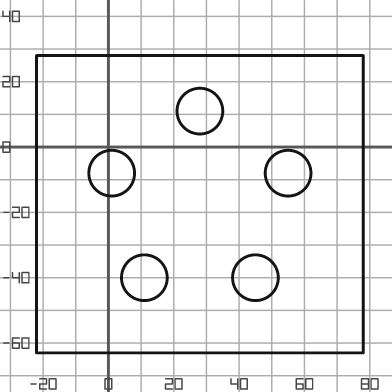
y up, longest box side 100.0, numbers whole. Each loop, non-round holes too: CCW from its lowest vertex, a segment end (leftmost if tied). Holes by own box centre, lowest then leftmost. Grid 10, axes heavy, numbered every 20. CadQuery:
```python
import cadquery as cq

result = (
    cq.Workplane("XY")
    .moveTo(-22.0, -63.0)
    .lineTo(78.0, -63.0)
    .lineTo(78.0, 28.0)
    .lineTo(-22.0, 28.0)
    .close()
    .moveTo(11.0, -40.0)
    .circle(7.0)
    .moveTo(45.0, -40.0)
    .circle(7.0)
    .moveTo(1.0, -8.0)
    .circle(7.0)
    .moveTo(55.0, -8.0)
    .circle(7.0)
    .moveTo(28.0, 11.0)
    .circle(7.0)
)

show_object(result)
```